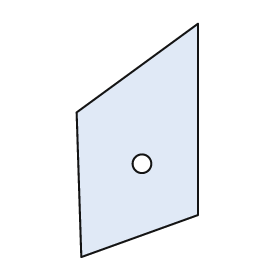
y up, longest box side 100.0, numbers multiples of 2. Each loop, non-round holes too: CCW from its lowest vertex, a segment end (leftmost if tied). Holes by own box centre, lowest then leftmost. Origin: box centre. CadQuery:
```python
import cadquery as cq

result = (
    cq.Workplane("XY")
    .moveTo(-24.0, -50.0)
    .lineTo(26.0, -32.0)
    .lineTo(26.0, 50.0)
    .lineTo(-26.0, 12.0)
    .close()
    .moveTo(2.0, -10.0)
    .circle(4.0)
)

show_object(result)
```